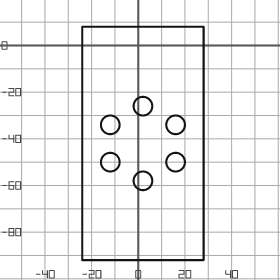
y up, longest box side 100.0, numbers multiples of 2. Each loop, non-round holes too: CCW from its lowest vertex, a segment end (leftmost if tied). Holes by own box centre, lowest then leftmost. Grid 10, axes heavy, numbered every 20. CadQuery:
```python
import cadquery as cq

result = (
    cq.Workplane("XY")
    .moveTo(-24.0, -92.0)
    .lineTo(28.0, -92.0)
    .lineTo(28.0, 8.0)
    .lineTo(-24.0, 8.0)
    .close()
    .moveTo(2.0, -58.0)
    .circle(4.0)
    .moveTo(-12.0, -50.0)
    .circle(4.0)
    .moveTo(16.0, -50.0)
    .circle(4.0)
    .moveTo(-12.0, -34.0)
    .circle(4.0)
    .moveTo(16.0, -34.0)
    .circle(4.0)
    .moveTo(2.0, -26.0)
    .circle(4.0)
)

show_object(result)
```